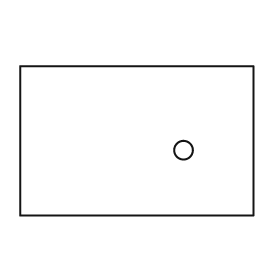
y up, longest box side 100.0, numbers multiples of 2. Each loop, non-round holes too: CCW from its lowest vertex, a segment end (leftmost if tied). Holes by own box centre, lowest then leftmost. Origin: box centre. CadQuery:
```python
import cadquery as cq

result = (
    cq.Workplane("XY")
    .moveTo(-50.0, -32.0)
    .lineTo(50.0, -32.0)
    .lineTo(50.0, 32.0)
    .lineTo(-50.0, 32.0)
    .close()
    .moveTo(20.0, -4.0)
    .circle(4.0)
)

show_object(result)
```